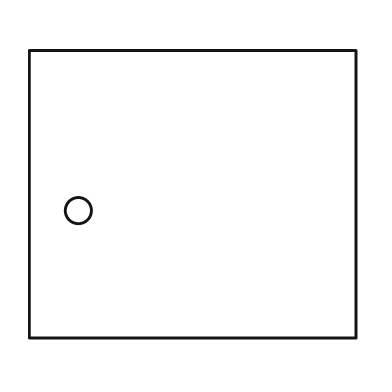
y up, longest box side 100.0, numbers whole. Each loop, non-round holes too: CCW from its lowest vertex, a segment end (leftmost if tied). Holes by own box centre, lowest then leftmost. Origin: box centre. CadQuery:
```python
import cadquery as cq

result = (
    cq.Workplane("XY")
    .moveTo(-50.0, -44.0)
    .lineTo(50.0, -44.0)
    .lineTo(50.0, 44.0)
    .lineTo(-50.0, 44.0)
    .close()
    .moveTo(-35.0, -5.0)
    .circle(4.0)
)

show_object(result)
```